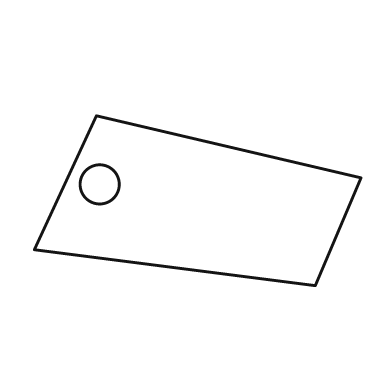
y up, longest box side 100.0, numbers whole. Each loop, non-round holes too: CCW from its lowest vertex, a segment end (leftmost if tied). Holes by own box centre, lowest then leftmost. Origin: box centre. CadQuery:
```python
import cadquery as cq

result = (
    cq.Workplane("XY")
    .moveTo(36.0, -26.0)
    .lineTo(50.0, 7.0)
    .lineTo(-31.0, 26.0)
    .lineTo(-50.0, -15.0)
    .close()
    .moveTo(-30.0, 5.0)
    .circle(6.0)
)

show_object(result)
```